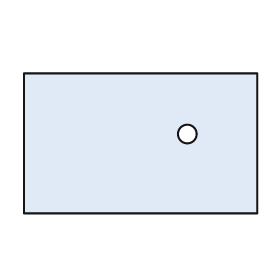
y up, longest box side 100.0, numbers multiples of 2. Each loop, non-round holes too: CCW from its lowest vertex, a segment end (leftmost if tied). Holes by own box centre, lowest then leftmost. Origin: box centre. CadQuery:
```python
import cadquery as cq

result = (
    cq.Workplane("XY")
    .moveTo(-50.0, -30.0)
    .lineTo(50.0, -30.0)
    .lineTo(50.0, 30.0)
    .lineTo(-50.0, 30.0)
    .close()
    .moveTo(20.0, 4.0)
    .circle(4.0)
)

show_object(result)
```